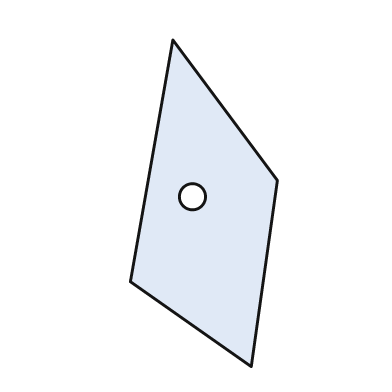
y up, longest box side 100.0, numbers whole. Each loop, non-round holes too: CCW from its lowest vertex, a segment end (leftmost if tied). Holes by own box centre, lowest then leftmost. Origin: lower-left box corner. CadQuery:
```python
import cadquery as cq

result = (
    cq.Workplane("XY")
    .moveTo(37.0, 0.0)
    .lineTo(45.0, 57.0)
    .lineTo(13.0, 100.0)
    .lineTo(0.0, 26.0)
    .close()
    .moveTo(19.0, 52.0)
    .circle(4.0)
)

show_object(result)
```